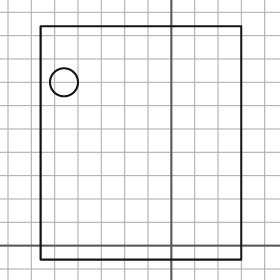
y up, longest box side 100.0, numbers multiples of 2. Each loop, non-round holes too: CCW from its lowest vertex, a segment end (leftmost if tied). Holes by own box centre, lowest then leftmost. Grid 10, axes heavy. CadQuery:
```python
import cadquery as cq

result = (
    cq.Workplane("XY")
    .moveTo(-56.0, -6.0)
    .lineTo(30.0, -6.0)
    .lineTo(30.0, 94.0)
    .lineTo(-56.0, 94.0)
    .close()
    .moveTo(-46.0, 70.0)
    .circle(6.0)
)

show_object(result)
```